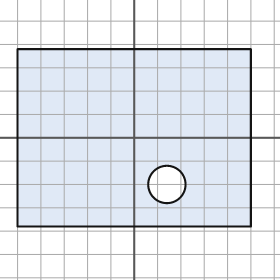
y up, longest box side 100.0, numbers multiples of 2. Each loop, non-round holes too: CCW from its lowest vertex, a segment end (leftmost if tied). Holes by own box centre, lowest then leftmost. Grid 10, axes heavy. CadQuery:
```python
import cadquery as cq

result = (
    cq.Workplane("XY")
    .moveTo(-50.0, -38.0)
    .lineTo(50.0, -38.0)
    .lineTo(50.0, 38.0)
    .lineTo(-50.0, 38.0)
    .close()
    .moveTo(14.0, -20.0)
    .circle(8.0)
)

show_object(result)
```